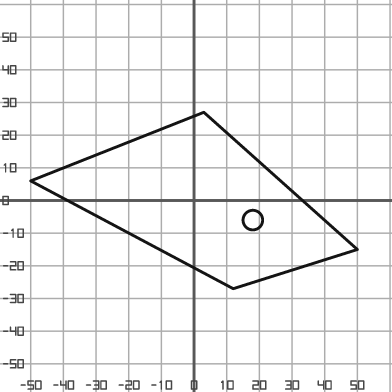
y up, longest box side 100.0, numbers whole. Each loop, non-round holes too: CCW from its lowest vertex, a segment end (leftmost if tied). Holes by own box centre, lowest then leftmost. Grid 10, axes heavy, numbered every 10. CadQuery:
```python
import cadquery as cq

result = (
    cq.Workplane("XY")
    .moveTo(12.0, -27.0)
    .lineTo(50.0, -15.0)
    .lineTo(3.0, 27.0)
    .lineTo(-50.0, 6.0)
    .close()
    .moveTo(18.0, -6.0)
    .circle(3.0)
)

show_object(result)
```